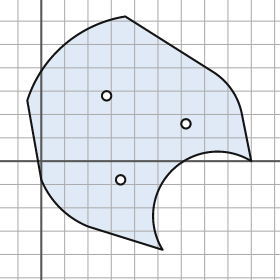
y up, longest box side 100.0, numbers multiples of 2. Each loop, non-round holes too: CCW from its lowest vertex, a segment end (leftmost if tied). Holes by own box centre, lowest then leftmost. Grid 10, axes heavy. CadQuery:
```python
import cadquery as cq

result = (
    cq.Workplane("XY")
    .moveTo(52.0, -38.0)
    .threePointArc((56.0, -4.0), (90.0, 0.0))
    .lineTo(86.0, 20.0)
    .threePointArc((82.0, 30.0), (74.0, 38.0))
    .lineTo(36.0, 62.0)
    .threePointArc((10.0, 50.0), (-6.0, 26.0))
    .lineTo(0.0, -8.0)
    .threePointArc((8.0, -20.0), (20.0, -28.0))
    .close()
    .moveTo(34.0, -8.0)
    .circle(2.0)
    .moveTo(62.0, 16.0)
    .circle(2.0)
    .moveTo(28.0, 28.0)
    .circle(2.0)
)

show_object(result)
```